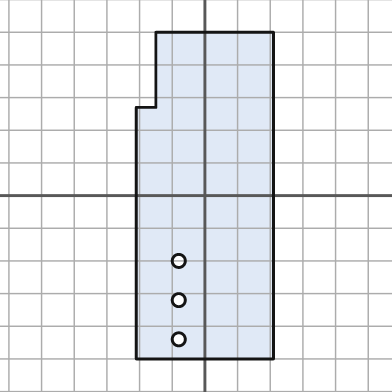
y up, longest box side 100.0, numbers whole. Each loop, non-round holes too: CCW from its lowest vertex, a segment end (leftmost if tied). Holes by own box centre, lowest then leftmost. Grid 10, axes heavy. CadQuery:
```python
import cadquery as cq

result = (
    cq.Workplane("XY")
    .moveTo(-21.0, -50.0)
    .lineTo(21.0, -50.0)
    .lineTo(21.0, 50.0)
    .lineTo(-15.0, 50.0)
    .lineTo(-15.0, 27.0)
    .lineTo(-21.0, 27.0)
    .close()
    .moveTo(-8.0, -44.0)
    .circle(2.0)
    .moveTo(-8.0, -32.0)
    .circle(2.0)
    .moveTo(-8.0, -20.0)
    .circle(2.0)
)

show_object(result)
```